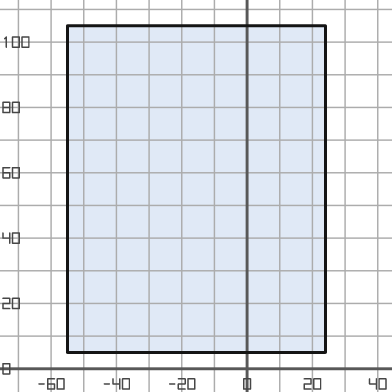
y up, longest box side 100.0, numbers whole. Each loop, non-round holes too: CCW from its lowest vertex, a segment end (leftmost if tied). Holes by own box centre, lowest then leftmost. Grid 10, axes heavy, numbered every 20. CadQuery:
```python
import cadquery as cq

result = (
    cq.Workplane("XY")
    .moveTo(-55.0, 5.0)
    .lineTo(24.0, 5.0)
    .lineTo(24.0, 105.0)
    .lineTo(-55.0, 105.0)
    .close()
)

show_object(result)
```